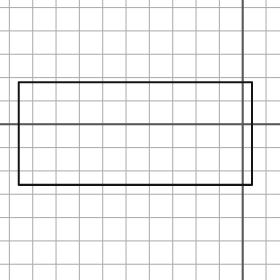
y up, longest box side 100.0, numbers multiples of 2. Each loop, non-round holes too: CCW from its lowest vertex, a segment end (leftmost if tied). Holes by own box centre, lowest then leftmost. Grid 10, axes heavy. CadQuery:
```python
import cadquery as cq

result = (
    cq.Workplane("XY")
    .moveTo(-96.0, -26.0)
    .lineTo(4.0, -26.0)
    .lineTo(4.0, 18.0)
    .lineTo(-96.0, 18.0)
    .close()
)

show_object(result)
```